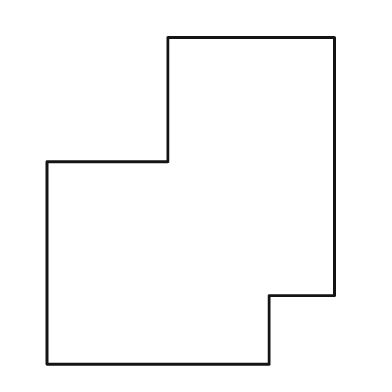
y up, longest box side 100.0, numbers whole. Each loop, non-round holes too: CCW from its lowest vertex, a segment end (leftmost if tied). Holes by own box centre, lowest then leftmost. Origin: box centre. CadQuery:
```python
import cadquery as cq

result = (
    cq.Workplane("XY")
    .moveTo(-44.0, -50.0)
    .lineTo(24.0, -50.0)
    .lineTo(24.0, -29.0)
    .lineTo(44.0, -29.0)
    .lineTo(44.0, 50.0)
    .lineTo(-7.0, 50.0)
    .lineTo(-7.0, 12.0)
    .lineTo(-44.0, 12.0)
    .close()
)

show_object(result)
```